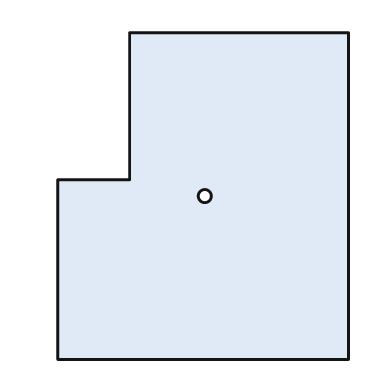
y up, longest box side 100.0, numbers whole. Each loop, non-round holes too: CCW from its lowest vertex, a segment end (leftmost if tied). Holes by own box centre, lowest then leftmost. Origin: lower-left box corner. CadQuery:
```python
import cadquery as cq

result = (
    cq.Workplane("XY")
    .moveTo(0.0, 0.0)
    .lineTo(89.0, 0.0)
    .lineTo(89.0, 100.0)
    .lineTo(22.0, 100.0)
    .lineTo(22.0, 55.0)
    .lineTo(0.0, 55.0)
    .close()
    .moveTo(45.0, 50.0)
    .circle(2.0)
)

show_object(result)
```